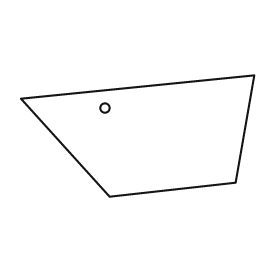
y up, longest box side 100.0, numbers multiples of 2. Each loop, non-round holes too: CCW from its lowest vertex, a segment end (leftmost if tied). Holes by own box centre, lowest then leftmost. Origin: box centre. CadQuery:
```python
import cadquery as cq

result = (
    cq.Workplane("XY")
    .moveTo(-12.0, -26.0)
    .lineTo(42.0, -20.0)
    .lineTo(50.0, 26.0)
    .lineTo(-50.0, 16.0)
    .close()
    .moveTo(-14.0, 12.0)
    .circle(2.0)
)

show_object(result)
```